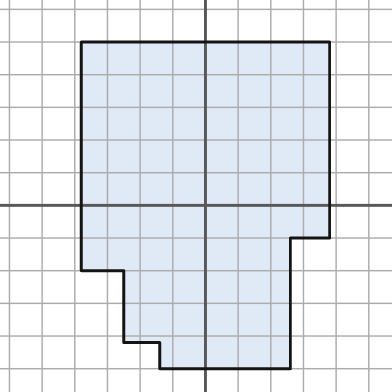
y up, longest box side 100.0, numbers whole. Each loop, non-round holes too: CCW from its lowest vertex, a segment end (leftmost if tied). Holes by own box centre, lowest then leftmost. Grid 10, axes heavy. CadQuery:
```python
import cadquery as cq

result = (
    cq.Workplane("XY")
    .moveTo(-14.0, -50.0)
    .lineTo(26.0, -50.0)
    .lineTo(26.0, -10.0)
    .lineTo(38.0, -10.0)
    .lineTo(38.0, 50.0)
    .lineTo(-38.0, 50.0)
    .lineTo(-38.0, -20.0)
    .lineTo(-25.0, -20.0)
    .lineTo(-25.0, -42.0)
    .lineTo(-14.0, -42.0)
    .close()
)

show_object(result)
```